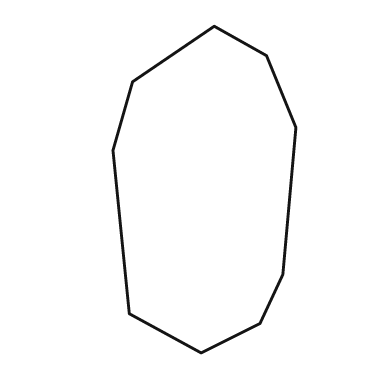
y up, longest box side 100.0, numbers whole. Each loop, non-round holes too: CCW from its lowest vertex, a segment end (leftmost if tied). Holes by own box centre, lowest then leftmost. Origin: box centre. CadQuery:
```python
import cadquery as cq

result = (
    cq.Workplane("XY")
    .moveTo(-1.0, -50.0)
    .lineTo(17.0, -41.0)
    .lineTo(24.0, -26.0)
    .lineTo(28.0, 19.0)
    .lineTo(19.0, 41.0)
    .lineTo(3.0, 50.0)
    .lineTo(-22.0, 33.0)
    .lineTo(-28.0, 12.0)
    .lineTo(-23.0, -38.0)
    .close()
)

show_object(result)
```